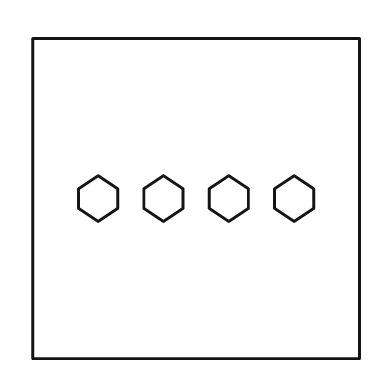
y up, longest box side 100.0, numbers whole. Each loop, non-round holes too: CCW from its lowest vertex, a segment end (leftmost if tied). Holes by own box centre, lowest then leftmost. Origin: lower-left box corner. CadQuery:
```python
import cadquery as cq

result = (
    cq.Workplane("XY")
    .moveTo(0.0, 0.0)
    .lineTo(100.0, 0.0)
    .lineTo(100.0, 98.0)
    .lineTo(0.0, 98.0)
    .close()
    .moveTo(20.0, 42.0)
    .lineTo(26.0, 46.0)
    .lineTo(26.0, 52.0)
    .lineTo(20.0, 56.0)
    .lineTo(14.0, 52.0)
    .lineTo(14.0, 46.0)
    .close()
    .moveTo(40.0, 42.0)
    .lineTo(46.0, 46.0)
    .lineTo(46.0, 52.0)
    .lineTo(40.0, 56.0)
    .lineTo(34.0, 52.0)
    .lineTo(34.0, 46.0)
    .close()
    .moveTo(60.0, 42.0)
    .lineTo(66.0, 46.0)
    .lineTo(66.0, 52.0)
    .lineTo(60.0, 56.0)
    .lineTo(54.0, 52.0)
    .lineTo(54.0, 46.0)
    .close()
    .moveTo(80.0, 42.0)
    .lineTo(86.0, 46.0)
    .lineTo(86.0, 52.0)
    .lineTo(80.0, 56.0)
    .lineTo(74.0, 52.0)
    .lineTo(74.0, 46.0)
    .close()
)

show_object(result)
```